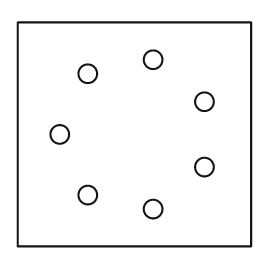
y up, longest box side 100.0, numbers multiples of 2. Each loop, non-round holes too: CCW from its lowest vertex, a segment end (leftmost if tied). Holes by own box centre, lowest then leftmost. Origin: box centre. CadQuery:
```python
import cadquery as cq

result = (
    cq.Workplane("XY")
    .moveTo(-50.0, -48.0)
    .lineTo(50.0, -48.0)
    .lineTo(50.0, 48.0)
    .lineTo(-50.0, 48.0)
    .close()
    .moveTo(8.0, -32.0)
    .circle(4.0)
    .moveTo(-20.0, -26.0)
    .circle(4.0)
    .moveTo(30.0, -14.0)
    .circle(4.0)
    .moveTo(-32.0, 0.0)
    .circle(4.0)
    .moveTo(30.0, 14.0)
    .circle(4.0)
    .moveTo(-20.0, 26.0)
    .circle(4.0)
    .moveTo(8.0, 32.0)
    .circle(4.0)
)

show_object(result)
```